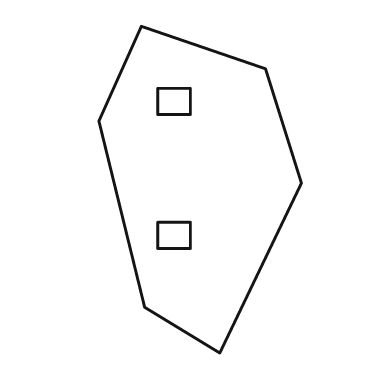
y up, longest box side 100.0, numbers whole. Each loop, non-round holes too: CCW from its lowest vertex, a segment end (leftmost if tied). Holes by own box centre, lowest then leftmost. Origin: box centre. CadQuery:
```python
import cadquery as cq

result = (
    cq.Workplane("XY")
    .moveTo(6.0, -50.0)
    .lineTo(31.0, 2.0)
    .lineTo(20.0, 37.0)
    .lineTo(-18.0, 50.0)
    .lineTo(-31.0, 21.0)
    .lineTo(-17.0, -36.0)
    .close()
    .moveTo(-13.0, -18.0)
    .lineTo(-3.0, -18.0)
    .lineTo(-3.0, -10.0)
    .lineTo(-13.0, -10.0)
    .close()
    .moveTo(-13.0, 23.0)
    .lineTo(-3.0, 23.0)
    .lineTo(-3.0, 31.0)
    .lineTo(-13.0, 31.0)
    .close()
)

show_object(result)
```